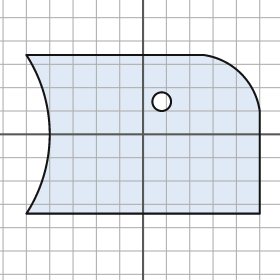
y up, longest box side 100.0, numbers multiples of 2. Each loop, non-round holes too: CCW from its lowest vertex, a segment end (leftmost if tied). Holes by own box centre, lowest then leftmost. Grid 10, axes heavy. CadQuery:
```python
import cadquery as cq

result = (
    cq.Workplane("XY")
    .moveTo(-50.0, -34.0)
    .lineTo(50.0, -34.0)
    .lineTo(50.0, 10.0)
    .threePointArc((42.0, 26.0), (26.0, 34.0))
    .lineTo(-50.0, 34.0)
    .threePointArc((-40.0, 0.0), (-50.0, -34.0))
    .close()
    .moveTo(8.0, 14.0)
    .circle(4.0)
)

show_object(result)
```